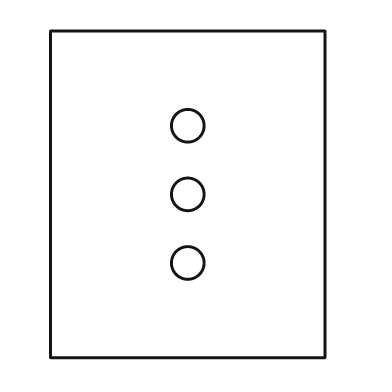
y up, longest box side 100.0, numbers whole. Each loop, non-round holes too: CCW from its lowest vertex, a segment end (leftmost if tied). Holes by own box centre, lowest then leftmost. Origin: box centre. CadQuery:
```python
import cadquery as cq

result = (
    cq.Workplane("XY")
    .moveTo(-42.0, -50.0)
    .lineTo(42.0, -50.0)
    .lineTo(42.0, 50.0)
    .lineTo(-42.0, 50.0)
    .close()
    .moveTo(0.0, -21.0)
    .circle(5.0)
    .moveTo(0.0, 0.0)
    .circle(5.0)
    .moveTo(0.0, 21.0)
    .circle(5.0)
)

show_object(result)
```